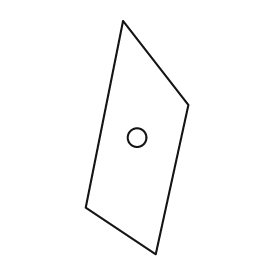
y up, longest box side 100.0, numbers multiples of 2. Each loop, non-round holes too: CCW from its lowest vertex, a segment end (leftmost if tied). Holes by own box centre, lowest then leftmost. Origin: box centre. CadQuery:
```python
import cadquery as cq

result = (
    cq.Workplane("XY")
    .moveTo(8.0, -50.0)
    .lineTo(22.0, 14.0)
    .lineTo(-6.0, 50.0)
    .lineTo(-22.0, -30.0)
    .close()
    .moveTo(0.0, 0.0)
    .circle(4.0)
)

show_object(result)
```